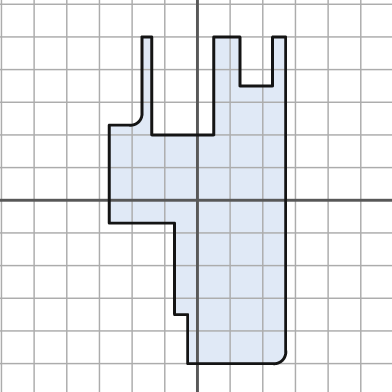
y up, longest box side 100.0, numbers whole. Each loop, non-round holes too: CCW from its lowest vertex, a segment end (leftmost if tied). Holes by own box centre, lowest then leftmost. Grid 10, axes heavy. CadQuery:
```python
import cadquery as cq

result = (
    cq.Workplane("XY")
    .moveTo(-3.0, -50.0)
    .lineTo(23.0, -50.0)
    .threePointArc((26.0, -49.0), (27.0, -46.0))
    .lineTo(27.0, 50.0)
    .lineTo(23.0, 50.0)
    .lineTo(23.0, 35.0)
    .lineTo(13.0, 35.0)
    .lineTo(13.0, 50.0)
    .lineTo(5.0, 50.0)
    .lineTo(5.0, 20.0)
    .lineTo(-14.0, 20.0)
    .lineTo(-14.0, 50.0)
    .lineTo(-17.0, 50.0)
    .lineTo(-17.0, 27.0)
    .threePointArc((-18.0, 24.0), (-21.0, 23.0))
    .lineTo(-27.0, 23.0)
    .lineTo(-27.0, -7.0)
    .lineTo(-7.0, -7.0)
    .lineTo(-7.0, -35.0)
    .lineTo(-3.0, -35.0)
    .close()
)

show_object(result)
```